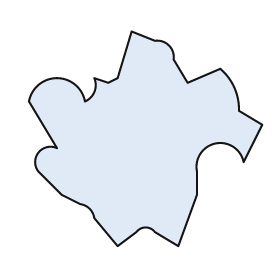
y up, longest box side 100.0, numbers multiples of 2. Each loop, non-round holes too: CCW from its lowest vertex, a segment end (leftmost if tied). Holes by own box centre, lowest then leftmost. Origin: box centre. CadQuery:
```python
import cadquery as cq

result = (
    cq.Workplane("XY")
    .moveTo(-12.0, -46.0)
    .lineTo(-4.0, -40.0)
    .threePointArc((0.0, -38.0), (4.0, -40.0))
    .lineTo(14.0, -46.0)
    .lineTo(22.0, -24.0)
    .lineTo(22.0, -14.0)
    .threePointArc((30.0, -2.0), (42.0, -10.0))
    .lineTo(50.0, 6.0)
    .lineTo(40.0, 12.0)
    .threePointArc((38.0, 22.0), (32.0, 30.0))
    .lineTo(18.0, 24.0)
    .lineTo(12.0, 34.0)
    .threePointArc((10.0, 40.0), (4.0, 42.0))
    .lineTo(-6.0, 46.0)
    .lineTo(-12.0, 26.0)
    .lineTo(-16.0, 24.0)
    .lineTo(-22.0, 26.0)
    .threePointArc((-22.0, 20.0), (-26.0, 16.0))
    .threePointArc((-38.0, 26.0), (-50.0, 16.0))
    .lineTo(-38.0, -4.0)
    .threePointArc((-46.0, -6.0), (-46.0, -14.0))
    .lineTo(-36.0, -24.0)
    .lineTo(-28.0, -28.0)
    .threePointArc((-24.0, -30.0), (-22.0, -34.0))
    .close()
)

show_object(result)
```